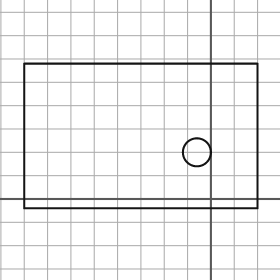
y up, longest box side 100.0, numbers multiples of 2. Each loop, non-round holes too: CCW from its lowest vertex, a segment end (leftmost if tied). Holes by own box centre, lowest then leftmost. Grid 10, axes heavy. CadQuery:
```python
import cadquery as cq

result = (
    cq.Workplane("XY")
    .moveTo(-80.0, -4.0)
    .lineTo(20.0, -4.0)
    .lineTo(20.0, 58.0)
    .lineTo(-80.0, 58.0)
    .close()
    .moveTo(-6.0, 20.0)
    .circle(6.0)
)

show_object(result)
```